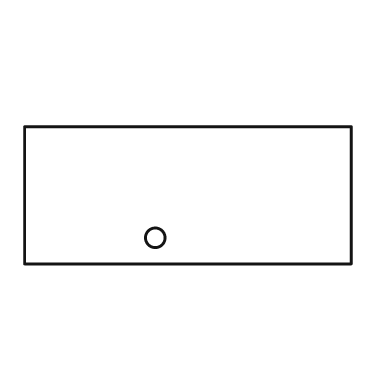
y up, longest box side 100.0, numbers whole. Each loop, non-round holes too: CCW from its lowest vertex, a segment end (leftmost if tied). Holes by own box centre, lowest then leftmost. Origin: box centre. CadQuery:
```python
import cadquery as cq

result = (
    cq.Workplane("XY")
    .moveTo(-50.0, -21.0)
    .lineTo(50.0, -21.0)
    .lineTo(50.0, 21.0)
    .lineTo(-50.0, 21.0)
    .close()
    .moveTo(-10.0, -13.0)
    .circle(3.0)
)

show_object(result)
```